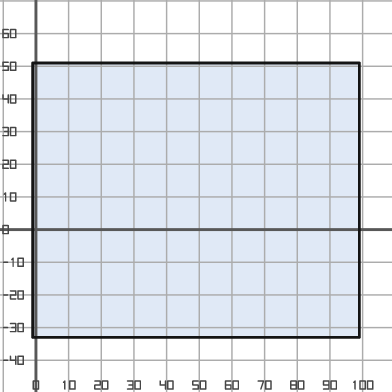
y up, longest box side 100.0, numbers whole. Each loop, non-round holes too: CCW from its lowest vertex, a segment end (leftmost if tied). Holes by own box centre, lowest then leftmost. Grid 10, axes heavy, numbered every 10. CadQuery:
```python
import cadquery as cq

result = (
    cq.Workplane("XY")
    .moveTo(-1.0, -33.0)
    .lineTo(99.0, -33.0)
    .lineTo(99.0, 51.0)
    .lineTo(-1.0, 51.0)
    .close()
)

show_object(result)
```